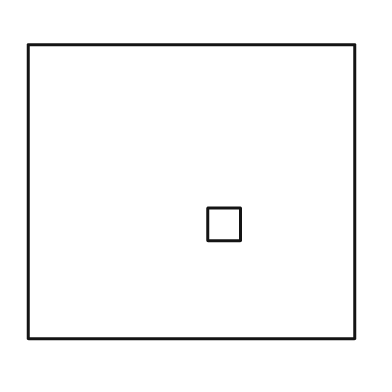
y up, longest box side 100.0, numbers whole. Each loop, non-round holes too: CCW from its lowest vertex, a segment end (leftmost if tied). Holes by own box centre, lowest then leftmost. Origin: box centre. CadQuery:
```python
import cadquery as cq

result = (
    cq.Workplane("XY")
    .moveTo(-50.0, -45.0)
    .lineTo(50.0, -45.0)
    .lineTo(50.0, 45.0)
    .lineTo(-50.0, 45.0)
    .close()
    .moveTo(5.0, -15.0)
    .lineTo(15.0, -15.0)
    .lineTo(15.0, -5.0)
    .lineTo(5.0, -5.0)
    .close()
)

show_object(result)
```